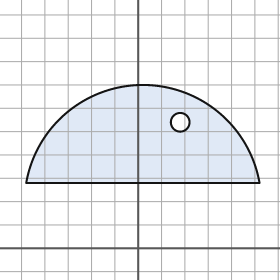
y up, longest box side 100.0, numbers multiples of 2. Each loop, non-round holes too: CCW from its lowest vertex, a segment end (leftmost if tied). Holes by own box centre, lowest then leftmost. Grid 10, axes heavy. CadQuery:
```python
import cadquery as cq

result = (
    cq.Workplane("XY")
    .moveTo(-48.0, 28.0)
    .lineTo(52.0, 28.0)
    .threePointArc((2.0, 70.0), (-48.0, 28.0))
    .close()
    .moveTo(18.0, 54.0)
    .circle(4.0)
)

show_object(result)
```